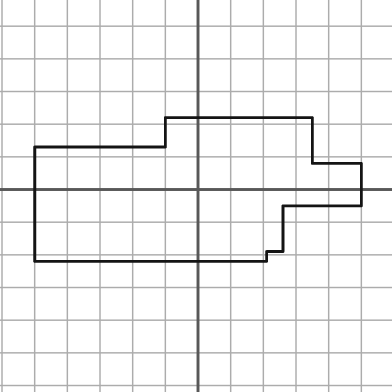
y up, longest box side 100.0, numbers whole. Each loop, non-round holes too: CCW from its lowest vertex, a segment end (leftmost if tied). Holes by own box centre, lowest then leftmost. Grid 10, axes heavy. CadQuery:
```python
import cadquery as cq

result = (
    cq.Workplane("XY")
    .moveTo(-50.0, -22.0)
    .lineTo(21.0, -22.0)
    .lineTo(21.0, -19.0)
    .lineTo(26.0, -19.0)
    .lineTo(26.0, -5.0)
    .lineTo(50.0, -5.0)
    .lineTo(50.0, 8.0)
    .lineTo(35.0, 8.0)
    .lineTo(35.0, 22.0)
    .lineTo(-10.0, 22.0)
    .lineTo(-10.0, 13.0)
    .lineTo(-50.0, 13.0)
    .close()
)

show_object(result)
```